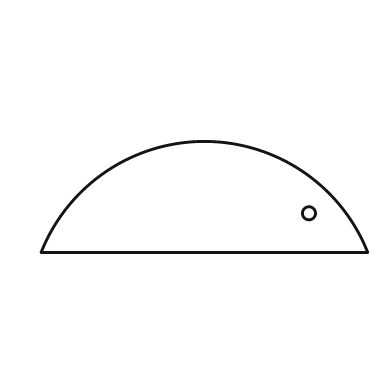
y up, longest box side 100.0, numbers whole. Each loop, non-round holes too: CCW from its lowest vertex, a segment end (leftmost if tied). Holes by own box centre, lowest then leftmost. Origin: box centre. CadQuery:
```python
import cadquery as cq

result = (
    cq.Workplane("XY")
    .moveTo(-50.0, -17.0)
    .lineTo(50.0, -17.0)
    .threePointArc((0.0, 17.0), (-50.0, -17.0))
    .close()
    .moveTo(32.0, -5.0)
    .circle(2.0)
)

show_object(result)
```